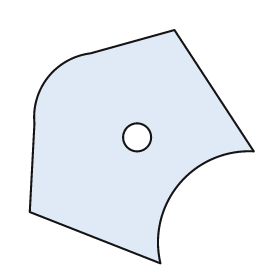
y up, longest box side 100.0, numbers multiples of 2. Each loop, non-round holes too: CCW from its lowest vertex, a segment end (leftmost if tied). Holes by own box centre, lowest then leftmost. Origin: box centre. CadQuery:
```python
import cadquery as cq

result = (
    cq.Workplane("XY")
    .moveTo(8.0, -50.0)
    .threePointArc((16.0, -16.0), (48.0, -2.0))
    .lineTo(14.0, 50.0)
    .lineTo(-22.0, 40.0)
    .threePointArc((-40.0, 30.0), (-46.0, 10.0))
    .lineTo(-48.0, -28.0)
    .close()
    .moveTo(-2.0, 4.0)
    .circle(6.0)
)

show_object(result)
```